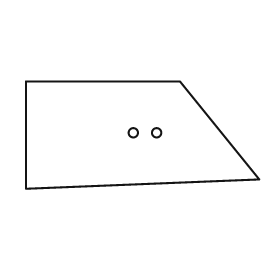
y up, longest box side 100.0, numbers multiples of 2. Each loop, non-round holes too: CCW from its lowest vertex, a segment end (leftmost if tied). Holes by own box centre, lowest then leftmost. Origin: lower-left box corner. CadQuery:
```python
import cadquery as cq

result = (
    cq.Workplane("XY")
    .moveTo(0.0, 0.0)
    .lineTo(100.0, 4.0)
    .lineTo(66.0, 46.0)
    .lineTo(0.0, 46.0)
    .close()
    .moveTo(46.0, 24.0)
    .circle(2.0)
    .moveTo(56.0, 24.0)
    .circle(2.0)
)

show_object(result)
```